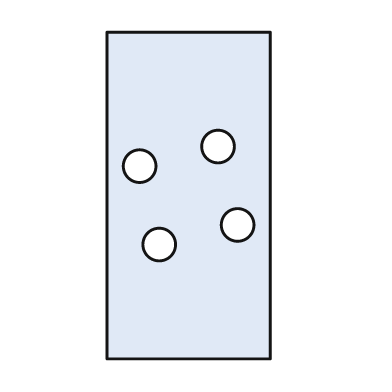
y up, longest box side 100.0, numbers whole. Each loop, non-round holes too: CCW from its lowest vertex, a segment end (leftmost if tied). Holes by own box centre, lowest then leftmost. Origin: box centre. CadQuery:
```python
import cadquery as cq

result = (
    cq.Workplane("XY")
    .moveTo(-25.0, -50.0)
    .lineTo(25.0, -50.0)
    .lineTo(25.0, 50.0)
    .lineTo(-25.0, 50.0)
    .close()
    .moveTo(-9.0, -15.0)
    .circle(5.0)
    .moveTo(15.0, -9.0)
    .circle(5.0)
    .moveTo(-15.0, 9.0)
    .circle(5.0)
    .moveTo(9.0, 15.0)
    .circle(5.0)
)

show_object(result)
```